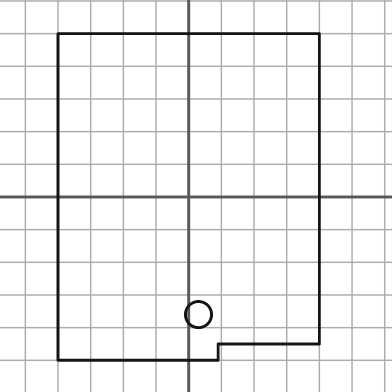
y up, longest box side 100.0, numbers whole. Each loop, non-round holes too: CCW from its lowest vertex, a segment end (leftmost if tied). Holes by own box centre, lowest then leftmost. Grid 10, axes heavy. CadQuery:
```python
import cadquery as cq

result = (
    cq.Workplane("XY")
    .moveTo(-40.0, -50.0)
    .lineTo(9.0, -50.0)
    .lineTo(9.0, -45.0)
    .lineTo(40.0, -45.0)
    .lineTo(40.0, 50.0)
    .lineTo(-40.0, 50.0)
    .close()
    .moveTo(3.0, -36.0)
    .circle(4.0)
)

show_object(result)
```